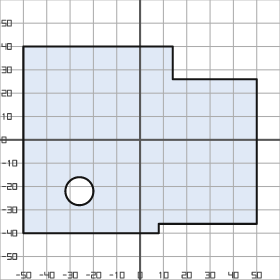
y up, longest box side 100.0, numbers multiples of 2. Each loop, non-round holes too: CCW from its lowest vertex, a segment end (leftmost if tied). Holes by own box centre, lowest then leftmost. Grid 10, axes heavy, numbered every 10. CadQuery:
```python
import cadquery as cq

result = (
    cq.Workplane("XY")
    .moveTo(-50.0, -40.0)
    .lineTo(8.0, -40.0)
    .lineTo(8.0, -36.0)
    .lineTo(50.0, -36.0)
    .lineTo(50.0, 26.0)
    .lineTo(14.0, 26.0)
    .lineTo(14.0, 40.0)
    .lineTo(-50.0, 40.0)
    .close()
    .moveTo(-26.0, -22.0)
    .circle(6.0)
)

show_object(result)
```